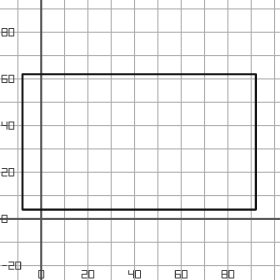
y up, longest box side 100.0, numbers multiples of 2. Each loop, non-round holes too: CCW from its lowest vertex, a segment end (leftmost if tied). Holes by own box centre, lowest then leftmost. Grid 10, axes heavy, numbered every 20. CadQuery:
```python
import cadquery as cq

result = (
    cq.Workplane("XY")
    .moveTo(-8.0, 4.0)
    .lineTo(92.0, 4.0)
    .lineTo(92.0, 62.0)
    .lineTo(-8.0, 62.0)
    .close()
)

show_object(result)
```